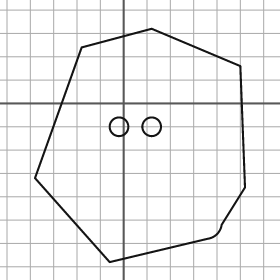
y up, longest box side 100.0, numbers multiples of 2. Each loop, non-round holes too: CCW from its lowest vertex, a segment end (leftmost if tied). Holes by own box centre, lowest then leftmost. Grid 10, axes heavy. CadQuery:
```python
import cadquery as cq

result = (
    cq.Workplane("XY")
    .moveTo(-6.0, -68.0)
    .lineTo(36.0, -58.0)
    .threePointArc((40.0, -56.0), (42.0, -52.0))
    .lineTo(52.0, -36.0)
    .lineTo(50.0, 16.0)
    .lineTo(12.0, 32.0)
    .lineTo(-18.0, 24.0)
    .lineTo(-38.0, -32.0)
    .close()
    .moveTo(-2.0, -10.0)
    .circle(4.0)
    .moveTo(12.0, -10.0)
    .circle(4.0)
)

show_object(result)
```